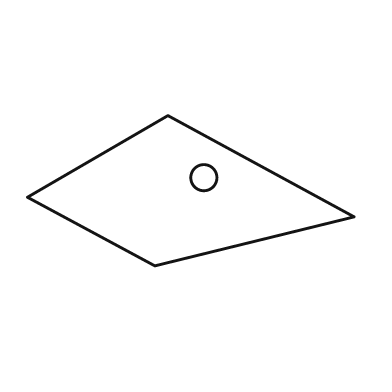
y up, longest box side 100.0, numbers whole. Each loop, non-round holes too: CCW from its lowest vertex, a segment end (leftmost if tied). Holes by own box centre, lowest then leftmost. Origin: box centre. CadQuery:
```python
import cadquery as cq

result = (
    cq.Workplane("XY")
    .moveTo(-11.0, -23.0)
    .lineTo(50.0, -8.0)
    .lineTo(-7.0, 23.0)
    .lineTo(-50.0, -2.0)
    .close()
    .moveTo(4.0, 4.0)
    .circle(4.0)
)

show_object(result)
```